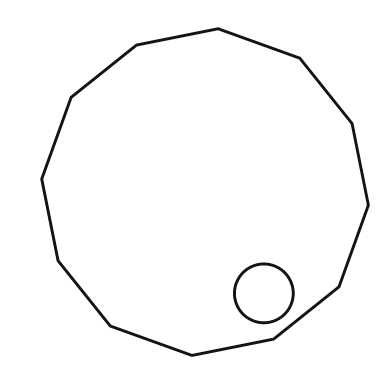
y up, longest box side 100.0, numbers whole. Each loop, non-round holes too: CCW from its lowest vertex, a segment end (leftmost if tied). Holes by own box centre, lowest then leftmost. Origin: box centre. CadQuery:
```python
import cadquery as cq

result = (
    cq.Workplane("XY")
    .moveTo(-4.0, -50.0)
    .lineTo(21.0, -45.0)
    .lineTo(41.0, -29.0)
    .lineTo(50.0, -4.0)
    .lineTo(45.0, 21.0)
    .lineTo(29.0, 41.0)
    .lineTo(4.0, 50.0)
    .lineTo(-21.0, 45.0)
    .lineTo(-41.0, 29.0)
    .lineTo(-50.0, 4.0)
    .lineTo(-45.0, -21.0)
    .lineTo(-29.0, -41.0)
    .close()
    .moveTo(18.0, -31.0)
    .circle(9.0)
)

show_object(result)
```